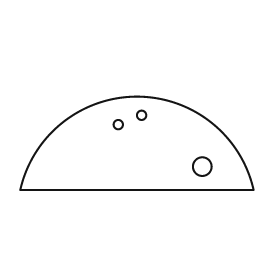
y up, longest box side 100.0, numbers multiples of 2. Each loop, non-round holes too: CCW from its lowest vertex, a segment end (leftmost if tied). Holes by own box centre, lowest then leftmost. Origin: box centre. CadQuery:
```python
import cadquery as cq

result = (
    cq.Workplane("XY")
    .moveTo(-50.0, -20.0)
    .lineTo(50.0, -20.0)
    .threePointArc((0.0, 20.0), (-50.0, -20.0))
    .close()
    .moveTo(28.0, -10.0)
    .circle(4.0)
    .moveTo(-8.0, 8.0)
    .circle(2.0)
    .moveTo(2.0, 12.0)
    .circle(2.0)
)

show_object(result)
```